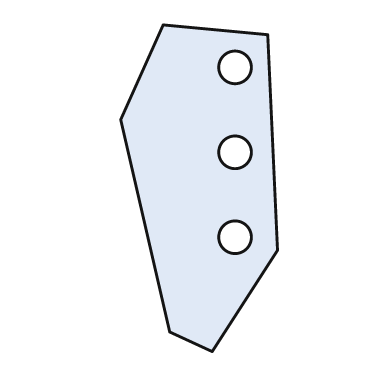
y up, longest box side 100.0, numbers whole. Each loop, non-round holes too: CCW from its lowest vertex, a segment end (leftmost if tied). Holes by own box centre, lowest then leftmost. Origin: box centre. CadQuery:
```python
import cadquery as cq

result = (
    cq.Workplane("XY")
    .moveTo(4.0, -50.0)
    .lineTo(24.0, -19.0)
    .lineTo(21.0, 47.0)
    .lineTo(-11.0, 50.0)
    .lineTo(-24.0, 21.0)
    .lineTo(-9.0, -44.0)
    .close()
    .moveTo(11.0, -15.0)
    .circle(5.0)
    .moveTo(11.0, 11.0)
    .circle(5.0)
    .moveTo(11.0, 37.0)
    .circle(5.0)
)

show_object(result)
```